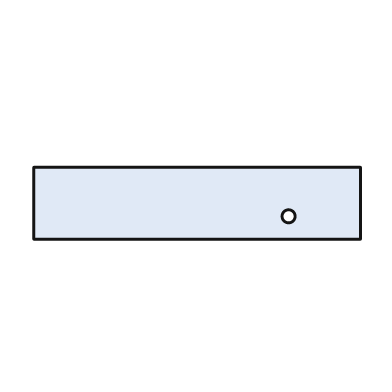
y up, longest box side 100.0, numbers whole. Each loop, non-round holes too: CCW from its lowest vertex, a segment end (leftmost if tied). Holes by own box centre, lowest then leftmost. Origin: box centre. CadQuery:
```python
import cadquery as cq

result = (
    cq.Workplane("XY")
    .moveTo(-50.0, -11.0)
    .lineTo(50.0, -11.0)
    .lineTo(50.0, 11.0)
    .lineTo(-50.0, 11.0)
    .close()
    .moveTo(28.0, -4.0)
    .circle(2.0)
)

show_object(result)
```